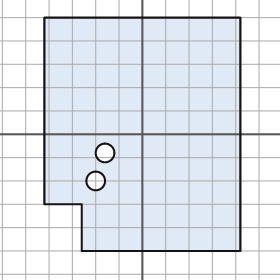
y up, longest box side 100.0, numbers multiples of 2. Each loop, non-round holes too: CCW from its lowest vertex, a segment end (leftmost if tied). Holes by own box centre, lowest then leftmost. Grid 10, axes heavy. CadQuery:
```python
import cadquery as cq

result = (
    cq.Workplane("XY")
    .moveTo(-26.0, -50.0)
    .lineTo(42.0, -50.0)
    .lineTo(42.0, 50.0)
    .lineTo(-42.0, 50.0)
    .lineTo(-42.0, -30.0)
    .lineTo(-26.0, -30.0)
    .close()
    .moveTo(-20.0, -20.0)
    .circle(4.0)
    .moveTo(-16.0, -8.0)
    .circle(4.0)
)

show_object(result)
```